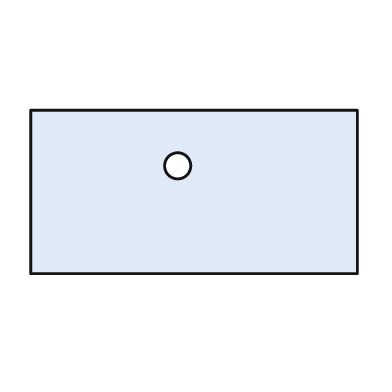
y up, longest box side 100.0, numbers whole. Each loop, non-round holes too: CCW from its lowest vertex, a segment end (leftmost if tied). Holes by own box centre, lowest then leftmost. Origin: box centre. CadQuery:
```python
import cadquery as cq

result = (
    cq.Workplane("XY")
    .moveTo(-50.0, -25.0)
    .lineTo(50.0, -25.0)
    .lineTo(50.0, 25.0)
    .lineTo(-50.0, 25.0)
    .close()
    .moveTo(-5.0, 8.0)
    .circle(4.0)
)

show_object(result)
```